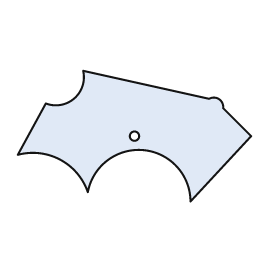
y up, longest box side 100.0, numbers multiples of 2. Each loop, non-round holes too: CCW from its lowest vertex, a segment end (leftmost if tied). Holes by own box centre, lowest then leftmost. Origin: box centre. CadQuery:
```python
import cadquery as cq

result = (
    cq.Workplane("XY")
    .moveTo(24.0, -28.0)
    .lineTo(50.0, 0.0)
    .lineTo(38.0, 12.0)
    .threePointArc((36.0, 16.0), (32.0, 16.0))
    .lineTo(-22.0, 28.0)
    .threePointArc((-26.0, 16.0), (-38.0, 14.0))
    .lineTo(-50.0, -8.0)
    .threePointArc((-32.0, -10.0), (-20.0, -24.0))
    .threePointArc((4.0, -6.0), (24.0, -28.0))
    .close()
    .moveTo(0.0, 0.0)
    .circle(2.0)
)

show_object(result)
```